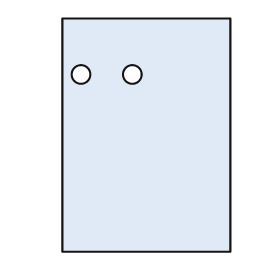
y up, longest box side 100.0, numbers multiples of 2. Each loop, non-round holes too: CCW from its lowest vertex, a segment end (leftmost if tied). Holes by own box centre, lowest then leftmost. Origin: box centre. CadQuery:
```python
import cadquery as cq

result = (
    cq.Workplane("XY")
    .moveTo(-36.0, -50.0)
    .lineTo(36.0, -50.0)
    .lineTo(36.0, 50.0)
    .lineTo(-36.0, 50.0)
    .close()
    .moveTo(-28.0, 26.0)
    .circle(4.0)
    .moveTo(-6.0, 26.0)
    .circle(4.0)
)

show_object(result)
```